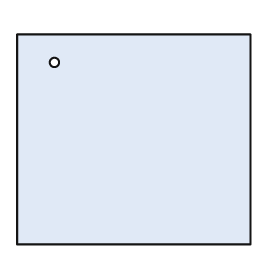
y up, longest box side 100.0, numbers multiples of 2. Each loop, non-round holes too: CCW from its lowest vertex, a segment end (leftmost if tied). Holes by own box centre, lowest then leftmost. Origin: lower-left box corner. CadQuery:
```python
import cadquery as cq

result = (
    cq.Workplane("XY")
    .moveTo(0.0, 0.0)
    .lineTo(100.0, 0.0)
    .lineTo(100.0, 90.0)
    .lineTo(0.0, 90.0)
    .close()
    .moveTo(16.0, 78.0)
    .circle(2.0)
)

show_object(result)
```